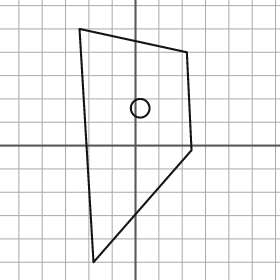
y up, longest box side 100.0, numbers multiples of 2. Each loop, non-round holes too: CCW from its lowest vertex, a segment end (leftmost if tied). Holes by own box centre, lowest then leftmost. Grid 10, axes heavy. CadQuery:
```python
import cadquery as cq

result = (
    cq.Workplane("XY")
    .moveTo(-18.0, -50.0)
    .lineTo(24.0, -2.0)
    .lineTo(22.0, 40.0)
    .lineTo(-24.0, 50.0)
    .close()
    .moveTo(2.0, 16.0)
    .circle(4.0)
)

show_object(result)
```